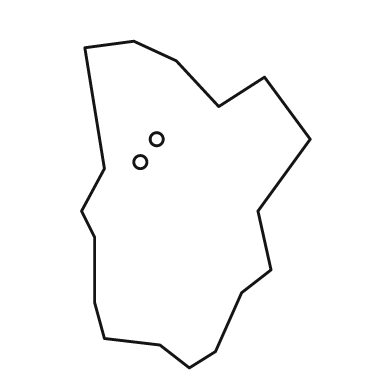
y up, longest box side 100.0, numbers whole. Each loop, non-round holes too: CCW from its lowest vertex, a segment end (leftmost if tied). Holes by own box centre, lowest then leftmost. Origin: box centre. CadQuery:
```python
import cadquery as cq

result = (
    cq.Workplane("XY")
    .moveTo(-2.0, -50.0)
    .lineTo(6.0, -45.0)
    .lineTo(14.0, -27.0)
    .lineTo(23.0, -20.0)
    .lineTo(19.0, -2.0)
    .lineTo(35.0, 20.0)
    .lineTo(21.0, 39.0)
    .lineTo(7.0, 30.0)
    .lineTo(-6.0, 44.0)
    .lineTo(-19.0, 50.0)
    .lineTo(-34.0, 48.0)
    .lineTo(-28.0, 11.0)
    .lineTo(-35.0, -2.0)
    .lineTo(-31.0, -10.0)
    .lineTo(-31.0, -30.0)
    .lineTo(-28.0, -41.0)
    .lineTo(-11.0, -43.0)
    .close()
    .moveTo(-17.0, 13.0)
    .circle(2.0)
    .moveTo(-12.0, 20.0)
    .circle(2.0)
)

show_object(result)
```